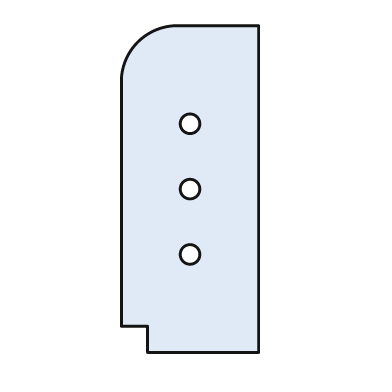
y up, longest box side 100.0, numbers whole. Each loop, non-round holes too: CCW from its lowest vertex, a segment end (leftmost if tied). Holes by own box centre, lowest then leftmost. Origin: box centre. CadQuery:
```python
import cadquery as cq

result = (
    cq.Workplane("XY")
    .moveTo(-13.0, -50.0)
    .lineTo(21.0, -50.0)
    .lineTo(21.0, 50.0)
    .lineTo(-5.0, 50.0)
    .threePointArc((-16.0, 45.0), (-21.0, 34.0))
    .lineTo(-21.0, -42.0)
    .lineTo(-13.0, -42.0)
    .close()
    .moveTo(0.0, -20.0)
    .circle(3.0)
    .moveTo(0.0, 0.0)
    .circle(3.0)
    .moveTo(0.0, 20.0)
    .circle(3.0)
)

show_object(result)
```